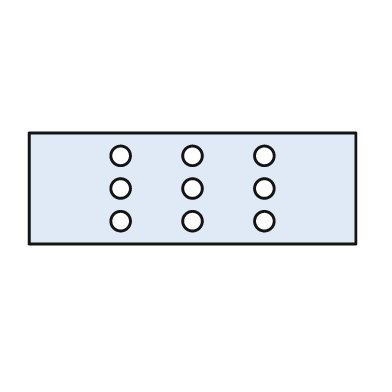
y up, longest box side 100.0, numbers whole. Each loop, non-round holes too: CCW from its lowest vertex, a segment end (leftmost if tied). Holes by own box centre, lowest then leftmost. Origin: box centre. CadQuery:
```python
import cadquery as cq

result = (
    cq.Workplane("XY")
    .moveTo(-50.0, -17.0)
    .lineTo(50.0, -17.0)
    .lineTo(50.0, 17.0)
    .lineTo(-50.0, 17.0)
    .close()
    .moveTo(-22.0, -10.0)
    .circle(3.0)
    .moveTo(0.0, -10.0)
    .circle(3.0)
    .moveTo(22.0, -10.0)
    .circle(3.0)
    .moveTo(-22.0, 0.0)
    .circle(3.0)
    .moveTo(0.0, 0.0)
    .circle(3.0)
    .moveTo(22.0, 0.0)
    .circle(3.0)
    .moveTo(-22.0, 10.0)
    .circle(3.0)
    .moveTo(0.0, 10.0)
    .circle(3.0)
    .moveTo(22.0, 10.0)
    .circle(3.0)
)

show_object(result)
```